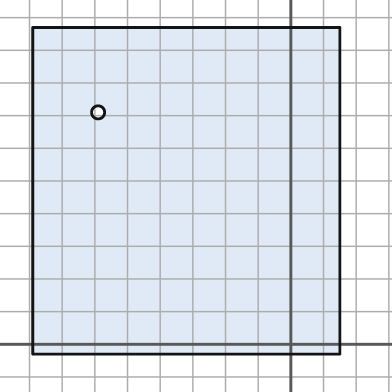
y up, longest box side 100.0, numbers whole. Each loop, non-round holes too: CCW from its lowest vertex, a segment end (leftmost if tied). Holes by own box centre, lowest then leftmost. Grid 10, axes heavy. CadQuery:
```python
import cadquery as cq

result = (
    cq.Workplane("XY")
    .moveTo(-79.0, -3.0)
    .lineTo(15.0, -3.0)
    .lineTo(15.0, 97.0)
    .lineTo(-79.0, 97.0)
    .close()
    .moveTo(-59.0, 71.0)
    .circle(2.0)
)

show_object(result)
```